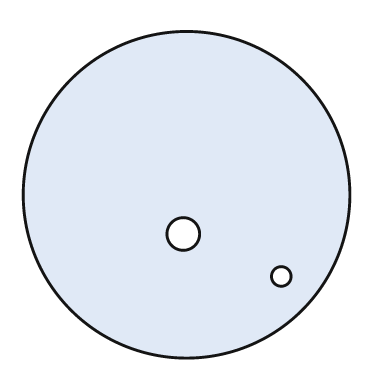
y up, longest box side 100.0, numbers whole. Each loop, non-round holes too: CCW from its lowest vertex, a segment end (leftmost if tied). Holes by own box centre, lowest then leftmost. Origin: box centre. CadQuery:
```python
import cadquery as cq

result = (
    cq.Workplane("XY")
    .moveTo(0.0, 0.0)
    .circle(50.0)
    .moveTo(29.0, -25.0)
    .circle(3.0)
    .moveTo(-1.0, -12.0)
    .circle(5.0)
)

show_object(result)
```